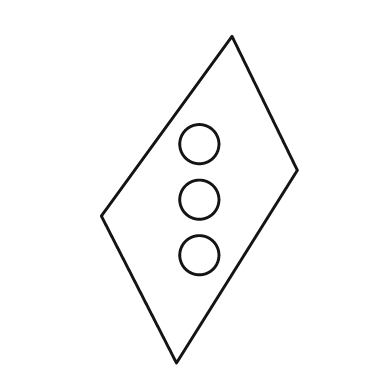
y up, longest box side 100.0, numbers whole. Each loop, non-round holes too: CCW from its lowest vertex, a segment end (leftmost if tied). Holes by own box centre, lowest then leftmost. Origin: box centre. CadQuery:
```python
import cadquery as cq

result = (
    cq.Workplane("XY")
    .moveTo(-7.0, -50.0)
    .lineTo(30.0, 9.0)
    .lineTo(10.0, 50.0)
    .lineTo(-30.0, -5.0)
    .close()
    .moveTo(0.0, -17.0)
    .circle(6.0)
    .moveTo(0.0, 0.0)
    .circle(6.0)
    .moveTo(0.0, 17.0)
    .circle(6.0)
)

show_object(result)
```